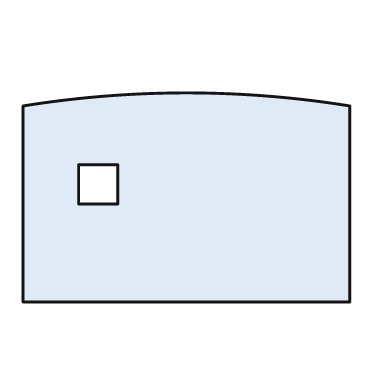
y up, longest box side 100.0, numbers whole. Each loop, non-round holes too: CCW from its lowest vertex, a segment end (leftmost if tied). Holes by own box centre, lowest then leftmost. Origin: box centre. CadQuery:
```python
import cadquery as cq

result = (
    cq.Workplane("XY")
    .moveTo(-50.0, -32.0)
    .lineTo(50.0, -32.0)
    .lineTo(50.0, 28.0)
    .threePointArc((0.0, 32.0), (-50.0, 28.0))
    .close()
    .moveTo(-33.0, -2.0)
    .lineTo(-21.0, -2.0)
    .lineTo(-21.0, 10.0)
    .lineTo(-33.0, 10.0)
    .close()
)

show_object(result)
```